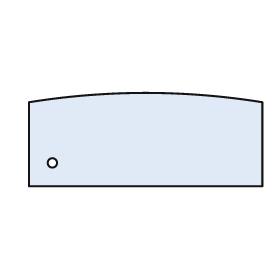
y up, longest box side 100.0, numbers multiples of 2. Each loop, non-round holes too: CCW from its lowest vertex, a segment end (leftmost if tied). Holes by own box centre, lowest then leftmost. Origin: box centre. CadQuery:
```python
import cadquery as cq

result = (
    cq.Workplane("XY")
    .moveTo(-50.0, -20.0)
    .lineTo(50.0, -20.0)
    .lineTo(50.0, 16.0)
    .threePointArc((0.0, 20.0), (-50.0, 16.0))
    .close()
    .moveTo(-40.0, -10.0)
    .circle(2.0)
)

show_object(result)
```